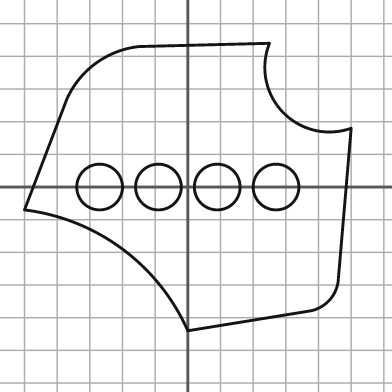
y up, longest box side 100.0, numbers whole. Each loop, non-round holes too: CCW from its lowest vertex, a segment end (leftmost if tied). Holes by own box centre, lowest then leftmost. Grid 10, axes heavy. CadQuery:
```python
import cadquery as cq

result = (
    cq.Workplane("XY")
    .moveTo(0.0, -44.0)
    .lineTo(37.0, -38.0)
    .threePointArc((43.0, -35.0), (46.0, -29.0))
    .lineTo(50.0, 18.0)
    .threePointArc((29.0, 23.0), (25.0, 44.0))
    .lineTo(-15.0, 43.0)
    .threePointArc((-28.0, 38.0), (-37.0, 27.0))
    .lineTo(-50.0, -7.0)
    .threePointArc((-20.0, -19.0), (0.0, -44.0))
    .close()
    .moveTo(-27.0, 0.0)
    .circle(7.0)
    .moveTo(-9.0, 0.0)
    .circle(7.0)
    .moveTo(9.0, 0.0)
    .circle(7.0)
    .moveTo(27.0, 0.0)
    .circle(7.0)
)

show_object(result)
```